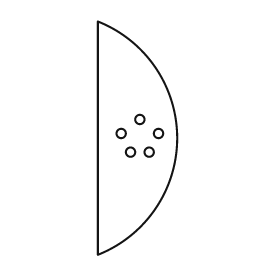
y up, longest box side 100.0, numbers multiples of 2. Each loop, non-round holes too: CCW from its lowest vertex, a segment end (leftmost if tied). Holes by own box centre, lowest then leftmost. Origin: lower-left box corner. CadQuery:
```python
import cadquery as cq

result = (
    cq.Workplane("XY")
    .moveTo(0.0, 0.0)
    .threePointArc((34.0, 50.0), (0.0, 100.0))
    .close()
    .moveTo(14.0, 44.0)
    .circle(2.0)
    .moveTo(22.0, 44.0)
    .circle(2.0)
    .moveTo(10.0, 52.0)
    .circle(2.0)
    .moveTo(26.0, 52.0)
    .circle(2.0)
    .moveTo(18.0, 58.0)
    .circle(2.0)
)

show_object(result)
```